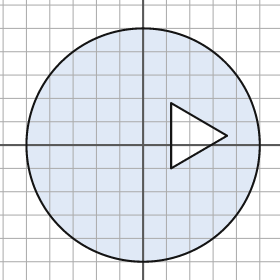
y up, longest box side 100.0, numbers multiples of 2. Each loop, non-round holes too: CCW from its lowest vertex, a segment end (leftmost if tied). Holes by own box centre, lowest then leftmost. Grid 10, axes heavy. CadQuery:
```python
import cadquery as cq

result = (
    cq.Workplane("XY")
    .moveTo(0.0, 0.0)
    .circle(50.0)
    .moveTo(12.0, -10.0)
    .lineTo(36.0, 4.0)
    .lineTo(12.0, 18.0)
    .close()
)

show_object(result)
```